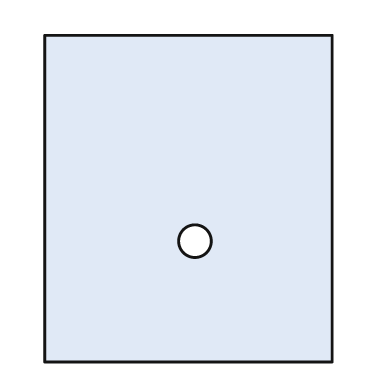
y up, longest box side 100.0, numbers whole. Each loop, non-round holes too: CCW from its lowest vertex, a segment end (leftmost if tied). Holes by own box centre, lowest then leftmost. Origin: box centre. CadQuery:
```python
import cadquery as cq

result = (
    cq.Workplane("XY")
    .moveTo(-44.0, -50.0)
    .lineTo(44.0, -50.0)
    .lineTo(44.0, 50.0)
    .lineTo(-44.0, 50.0)
    .close()
    .moveTo(2.0, -13.0)
    .circle(5.0)
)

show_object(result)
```